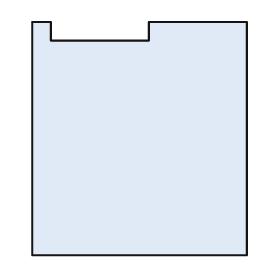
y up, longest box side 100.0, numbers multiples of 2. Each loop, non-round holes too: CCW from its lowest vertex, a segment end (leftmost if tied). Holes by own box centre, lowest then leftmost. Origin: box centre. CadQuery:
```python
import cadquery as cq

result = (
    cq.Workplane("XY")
    .moveTo(-46.0, -50.0)
    .lineTo(46.0, -50.0)
    .lineTo(46.0, 50.0)
    .lineTo(4.0, 50.0)
    .lineTo(4.0, 42.0)
    .lineTo(-38.0, 42.0)
    .lineTo(-38.0, 50.0)
    .lineTo(-46.0, 50.0)
    .close()
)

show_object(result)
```